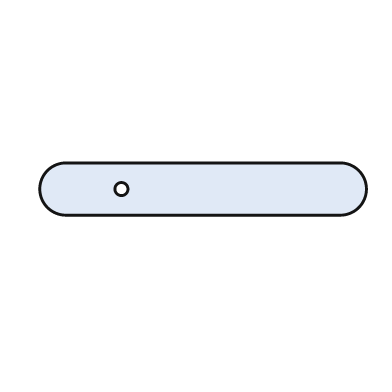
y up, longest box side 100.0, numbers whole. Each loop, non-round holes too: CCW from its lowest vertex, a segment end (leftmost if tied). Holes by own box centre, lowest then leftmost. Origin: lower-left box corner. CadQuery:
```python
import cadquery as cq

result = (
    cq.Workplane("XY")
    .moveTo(8.0, 0.0)
    .lineTo(92.0, 0.0)
    .threePointArc((100.0, 8.0), (92.0, 16.0))
    .lineTo(8.0, 16.0)
    .threePointArc((0.0, 8.0), (8.0, 0.0))
    .close()
    .moveTo(25.0, 8.0)
    .circle(2.0)
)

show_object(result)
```